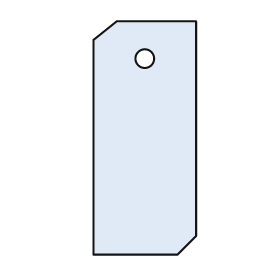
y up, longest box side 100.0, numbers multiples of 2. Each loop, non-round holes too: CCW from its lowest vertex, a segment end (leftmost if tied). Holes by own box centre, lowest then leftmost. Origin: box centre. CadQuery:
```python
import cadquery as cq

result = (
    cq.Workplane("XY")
    .moveTo(-22.0, -50.0)
    .lineTo(14.0, -50.0)
    .lineTo(22.0, -42.0)
    .lineTo(22.0, 50.0)
    .lineTo(-12.0, 50.0)
    .lineTo(-22.0, 42.0)
    .close()
    .moveTo(0.0, 34.0)
    .circle(4.0)
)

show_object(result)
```